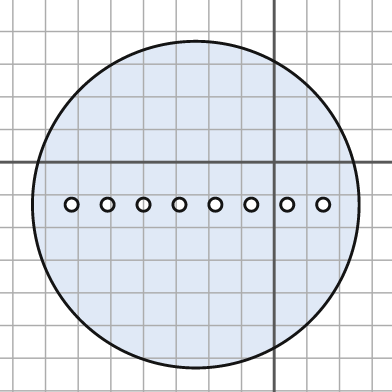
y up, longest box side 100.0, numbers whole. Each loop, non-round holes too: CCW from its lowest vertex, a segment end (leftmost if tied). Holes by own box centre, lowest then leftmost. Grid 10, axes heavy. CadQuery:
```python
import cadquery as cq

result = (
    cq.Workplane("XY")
    .moveTo(-24.0, -13.0)
    .circle(50.0)
    .moveTo(-62.0, -13.0)
    .circle(2.0)
    .moveTo(-51.0, -13.0)
    .circle(2.0)
    .moveTo(-40.0, -13.0)
    .circle(2.0)
    .moveTo(-29.0, -13.0)
    .circle(2.0)
    .moveTo(-18.0, -13.0)
    .circle(2.0)
    .moveTo(-7.0, -13.0)
    .circle(2.0)
    .moveTo(4.0, -13.0)
    .circle(2.0)
    .moveTo(15.0, -13.0)
    .circle(2.0)
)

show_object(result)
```